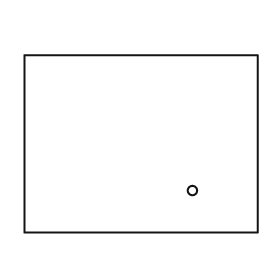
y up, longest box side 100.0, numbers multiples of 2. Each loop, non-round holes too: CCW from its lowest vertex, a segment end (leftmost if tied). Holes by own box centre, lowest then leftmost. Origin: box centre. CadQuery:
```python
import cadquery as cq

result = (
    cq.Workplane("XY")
    .moveTo(-50.0, -38.0)
    .lineTo(50.0, -38.0)
    .lineTo(50.0, 38.0)
    .lineTo(-50.0, 38.0)
    .close()
    .moveTo(22.0, -20.0)
    .circle(2.0)
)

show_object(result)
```